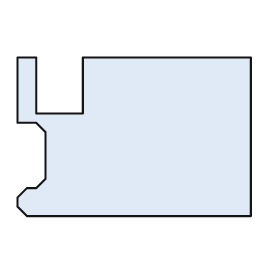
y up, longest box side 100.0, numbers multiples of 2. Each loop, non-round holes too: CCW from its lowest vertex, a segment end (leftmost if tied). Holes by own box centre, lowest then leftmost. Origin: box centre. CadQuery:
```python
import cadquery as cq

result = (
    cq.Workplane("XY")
    .moveTo(-46.0, -34.0)
    .lineTo(50.0, -34.0)
    .lineTo(50.0, 34.0)
    .lineTo(-22.0, 34.0)
    .lineTo(-22.0, 10.0)
    .lineTo(-42.0, 10.0)
    .lineTo(-42.0, 34.0)
    .lineTo(-50.0, 34.0)
    .lineTo(-50.0, 6.0)
    .lineTo(-42.0, 6.0)
    .lineTo(-38.0, 2.0)
    .lineTo(-38.0, -18.0)
    .lineTo(-42.0, -22.0)
    .lineTo(-46.0, -22.0)
    .lineTo(-50.0, -26.0)
    .lineTo(-50.0, -30.0)
    .close()
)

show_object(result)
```